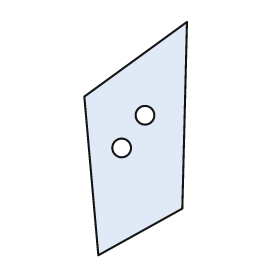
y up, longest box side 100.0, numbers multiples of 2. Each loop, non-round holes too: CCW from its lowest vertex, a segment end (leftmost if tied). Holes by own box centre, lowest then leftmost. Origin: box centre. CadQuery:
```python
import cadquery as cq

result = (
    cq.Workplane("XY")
    .moveTo(-16.0, -50.0)
    .lineTo(20.0, -30.0)
    .lineTo(22.0, 50.0)
    .lineTo(-22.0, 18.0)
    .close()
    .moveTo(-6.0, -4.0)
    .circle(4.0)
    .moveTo(4.0, 10.0)
    .circle(4.0)
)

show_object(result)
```